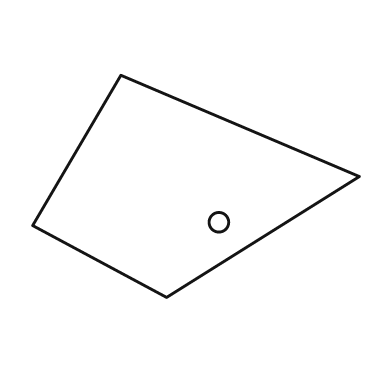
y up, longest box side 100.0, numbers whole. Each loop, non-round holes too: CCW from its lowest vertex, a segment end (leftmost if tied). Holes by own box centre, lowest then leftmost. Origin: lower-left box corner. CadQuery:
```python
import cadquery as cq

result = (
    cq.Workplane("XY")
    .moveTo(41.0, 0.0)
    .lineTo(100.0, 37.0)
    .lineTo(27.0, 68.0)
    .lineTo(0.0, 22.0)
    .close()
    .moveTo(57.0, 23.0)
    .circle(3.0)
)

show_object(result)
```